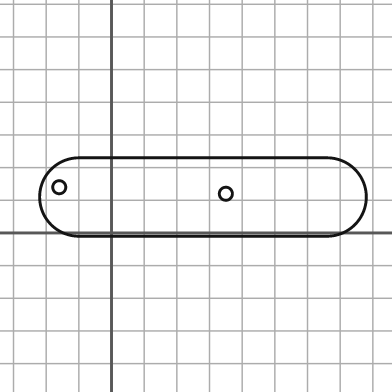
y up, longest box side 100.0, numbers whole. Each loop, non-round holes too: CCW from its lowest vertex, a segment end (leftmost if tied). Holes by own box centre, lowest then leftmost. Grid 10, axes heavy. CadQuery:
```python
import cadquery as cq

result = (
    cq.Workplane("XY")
    .moveTo(-10.0, -1.0)
    .lineTo(66.0, -1.0)
    .threePointArc((78.0, 11.0), (66.0, 23.0))
    .lineTo(-10.0, 23.0)
    .threePointArc((-22.0, 11.0), (-10.0, -1.0))
    .close()
    .moveTo(35.0, 12.0)
    .circle(2.0)
    .moveTo(-16.0, 14.0)
    .circle(2.0)
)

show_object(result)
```